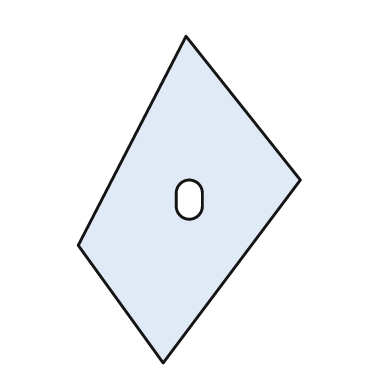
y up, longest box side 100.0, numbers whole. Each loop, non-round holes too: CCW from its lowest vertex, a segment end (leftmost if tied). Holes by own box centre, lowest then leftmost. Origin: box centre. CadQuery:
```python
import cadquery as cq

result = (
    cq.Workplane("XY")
    .moveTo(-8.0, -50.0)
    .lineTo(34.0, 6.0)
    .lineTo(-1.0, 50.0)
    .lineTo(-34.0, -14.0)
    .close()
    .moveTo(-4.0, -2.0)
    .threePointArc((0.0, -6.0), (4.0, -2.0))
    .lineTo(4.0, 2.0)
    .threePointArc((0.0, 6.0), (-4.0, 2.0))
    .close()
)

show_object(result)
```